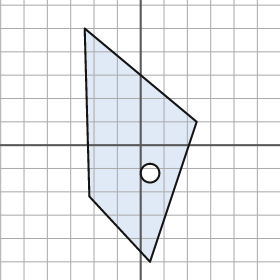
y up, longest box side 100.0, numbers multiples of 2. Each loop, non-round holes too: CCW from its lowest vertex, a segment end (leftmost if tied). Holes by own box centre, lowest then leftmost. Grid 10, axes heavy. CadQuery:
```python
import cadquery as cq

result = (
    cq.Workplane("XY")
    .moveTo(4.0, -50.0)
    .lineTo(24.0, 10.0)
    .lineTo(-24.0, 50.0)
    .lineTo(-22.0, -22.0)
    .close()
    .moveTo(4.0, -12.0)
    .circle(4.0)
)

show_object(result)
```